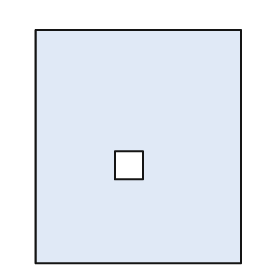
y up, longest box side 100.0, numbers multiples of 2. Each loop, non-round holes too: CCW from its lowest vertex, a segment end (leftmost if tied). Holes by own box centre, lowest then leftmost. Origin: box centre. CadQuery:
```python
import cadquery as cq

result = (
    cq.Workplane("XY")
    .moveTo(-44.0, -50.0)
    .lineTo(44.0, -50.0)
    .lineTo(44.0, 50.0)
    .lineTo(-44.0, 50.0)
    .close()
    .moveTo(-10.0, -14.0)
    .lineTo(2.0, -14.0)
    .lineTo(2.0, -2.0)
    .lineTo(-10.0, -2.0)
    .close()
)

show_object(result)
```